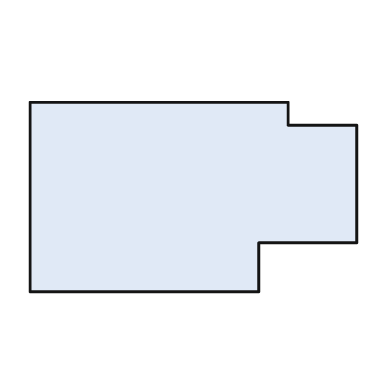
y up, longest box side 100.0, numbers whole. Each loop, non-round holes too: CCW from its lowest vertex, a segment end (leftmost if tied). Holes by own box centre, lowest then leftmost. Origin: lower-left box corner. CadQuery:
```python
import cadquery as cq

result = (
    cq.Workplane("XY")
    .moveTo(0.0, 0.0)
    .lineTo(70.0, 0.0)
    .lineTo(70.0, 15.0)
    .lineTo(100.0, 15.0)
    .lineTo(100.0, 51.0)
    .lineTo(79.0, 51.0)
    .lineTo(79.0, 58.0)
    .lineTo(0.0, 58.0)
    .close()
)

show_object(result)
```